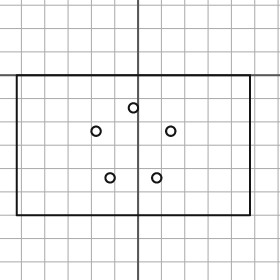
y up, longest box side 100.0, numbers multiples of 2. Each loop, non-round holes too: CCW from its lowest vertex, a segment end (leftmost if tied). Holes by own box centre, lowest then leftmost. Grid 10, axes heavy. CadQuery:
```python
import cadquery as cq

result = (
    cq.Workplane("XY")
    .moveTo(-52.0, -60.0)
    .lineTo(48.0, -60.0)
    .lineTo(48.0, 0.0)
    .lineTo(-52.0, 0.0)
    .close()
    .moveTo(-12.0, -44.0)
    .circle(2.0)
    .moveTo(8.0, -44.0)
    .circle(2.0)
    .moveTo(-18.0, -24.0)
    .circle(2.0)
    .moveTo(14.0, -24.0)
    .circle(2.0)
    .moveTo(-2.0, -14.0)
    .circle(2.0)
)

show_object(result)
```